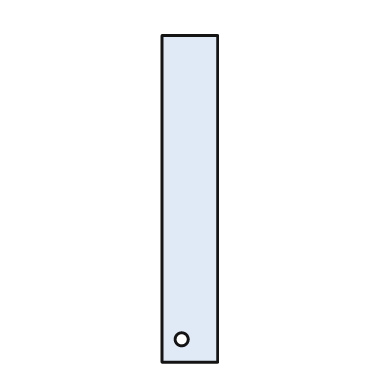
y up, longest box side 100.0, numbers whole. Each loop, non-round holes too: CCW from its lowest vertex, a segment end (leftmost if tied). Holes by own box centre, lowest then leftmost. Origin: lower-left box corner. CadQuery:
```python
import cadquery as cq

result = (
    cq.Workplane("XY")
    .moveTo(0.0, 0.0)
    .lineTo(17.0, 0.0)
    .lineTo(17.0, 100.0)
    .lineTo(0.0, 100.0)
    .close()
    .moveTo(6.0, 7.0)
    .circle(2.0)
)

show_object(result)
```